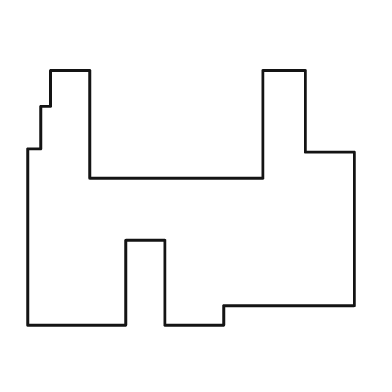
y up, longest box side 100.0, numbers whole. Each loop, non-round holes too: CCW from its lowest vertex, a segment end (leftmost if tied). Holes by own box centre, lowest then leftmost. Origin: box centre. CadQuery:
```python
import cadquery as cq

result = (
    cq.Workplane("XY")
    .moveTo(-50.0, -39.0)
    .lineTo(-20.0, -39.0)
    .lineTo(-20.0, -13.0)
    .lineTo(-8.0, -13.0)
    .lineTo(-8.0, -39.0)
    .lineTo(10.0, -39.0)
    .lineTo(10.0, -33.0)
    .lineTo(50.0, -33.0)
    .lineTo(50.0, 14.0)
    .lineTo(35.0, 14.0)
    .lineTo(35.0, 39.0)
    .lineTo(22.0, 39.0)
    .lineTo(22.0, 6.0)
    .lineTo(-31.0, 6.0)
    .lineTo(-31.0, 39.0)
    .lineTo(-43.0, 39.0)
    .lineTo(-43.0, 28.0)
    .lineTo(-46.0, 28.0)
    .lineTo(-46.0, 15.0)
    .lineTo(-50.0, 15.0)
    .close()
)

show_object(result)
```